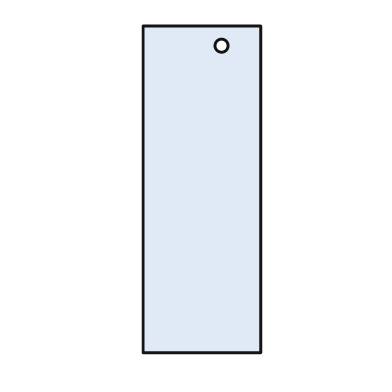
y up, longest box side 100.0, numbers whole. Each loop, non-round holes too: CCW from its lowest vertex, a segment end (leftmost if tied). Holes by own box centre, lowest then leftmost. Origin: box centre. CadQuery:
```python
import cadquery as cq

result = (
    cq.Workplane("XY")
    .moveTo(-18.0, -50.0)
    .lineTo(18.0, -50.0)
    .lineTo(18.0, 50.0)
    .lineTo(-18.0, 50.0)
    .close()
    .moveTo(6.0, 44.0)
    .circle(2.0)
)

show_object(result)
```